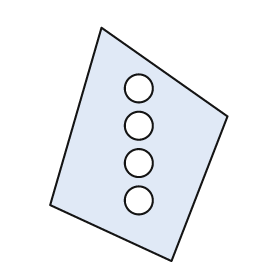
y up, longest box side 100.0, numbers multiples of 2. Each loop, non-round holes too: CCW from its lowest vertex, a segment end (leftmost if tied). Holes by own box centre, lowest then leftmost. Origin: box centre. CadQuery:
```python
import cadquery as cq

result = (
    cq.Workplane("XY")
    .moveTo(14.0, -50.0)
    .lineTo(38.0, 12.0)
    .lineTo(-16.0, 50.0)
    .lineTo(-38.0, -26.0)
    .close()
    .moveTo(0.0, -24.0)
    .circle(6.0)
    .moveTo(0.0, -8.0)
    .circle(6.0)
    .moveTo(0.0, 8.0)
    .circle(6.0)
    .moveTo(0.0, 24.0)
    .circle(6.0)
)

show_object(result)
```